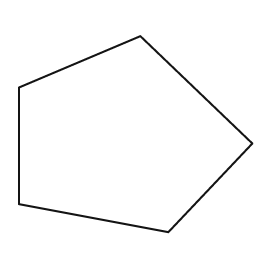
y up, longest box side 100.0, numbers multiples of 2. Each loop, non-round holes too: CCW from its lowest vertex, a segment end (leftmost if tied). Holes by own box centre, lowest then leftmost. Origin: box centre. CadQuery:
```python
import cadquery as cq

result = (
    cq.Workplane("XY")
    .moveTo(14.0, -42.0)
    .lineTo(50.0, -4.0)
    .lineTo(2.0, 42.0)
    .lineTo(-50.0, 20.0)
    .lineTo(-50.0, -30.0)
    .close()
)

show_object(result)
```